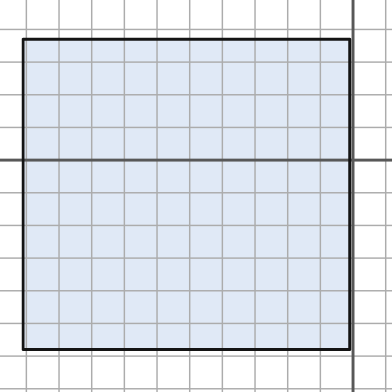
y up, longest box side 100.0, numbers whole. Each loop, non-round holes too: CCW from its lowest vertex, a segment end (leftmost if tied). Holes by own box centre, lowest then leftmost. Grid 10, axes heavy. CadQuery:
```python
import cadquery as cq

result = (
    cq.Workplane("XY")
    .moveTo(-101.0, -58.0)
    .lineTo(-1.0, -58.0)
    .lineTo(-1.0, 37.0)
    .lineTo(-101.0, 37.0)
    .close()
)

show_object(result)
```